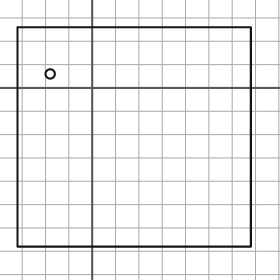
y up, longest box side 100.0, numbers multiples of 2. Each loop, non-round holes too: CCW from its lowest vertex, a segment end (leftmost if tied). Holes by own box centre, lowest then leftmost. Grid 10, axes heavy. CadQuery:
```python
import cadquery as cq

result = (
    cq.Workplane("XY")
    .moveTo(-32.0, -68.0)
    .lineTo(68.0, -68.0)
    .lineTo(68.0, 26.0)
    .lineTo(-32.0, 26.0)
    .close()
    .moveTo(-18.0, 6.0)
    .circle(2.0)
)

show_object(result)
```